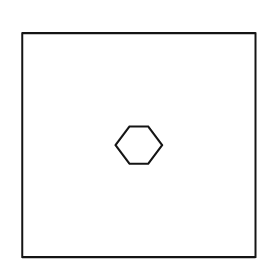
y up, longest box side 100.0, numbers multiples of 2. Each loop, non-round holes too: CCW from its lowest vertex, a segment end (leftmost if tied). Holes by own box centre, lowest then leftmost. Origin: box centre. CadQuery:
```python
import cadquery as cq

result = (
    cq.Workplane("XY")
    .moveTo(-50.0, -48.0)
    .lineTo(50.0, -48.0)
    .lineTo(50.0, 48.0)
    .lineTo(-50.0, 48.0)
    .close()
    .moveTo(-4.0, -8.0)
    .lineTo(4.0, -8.0)
    .lineTo(10.0, 0.0)
    .lineTo(4.0, 8.0)
    .lineTo(-4.0, 8.0)
    .lineTo(-10.0, 0.0)
    .close()
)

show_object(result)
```